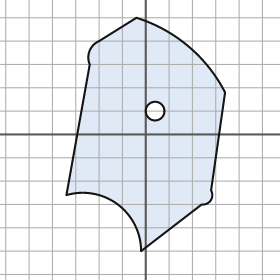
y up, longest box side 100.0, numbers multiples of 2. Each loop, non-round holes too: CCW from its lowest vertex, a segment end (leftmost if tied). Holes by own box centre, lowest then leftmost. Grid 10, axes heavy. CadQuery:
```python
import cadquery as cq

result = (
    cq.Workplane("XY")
    .moveTo(-2.0, -50.0)
    .lineTo(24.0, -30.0)
    .threePointArc((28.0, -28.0), (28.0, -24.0))
    .lineTo(34.0, 18.0)
    .threePointArc((18.0, 38.0), (-4.0, 50.0))
    .lineTo(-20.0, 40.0)
    .threePointArc((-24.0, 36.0), (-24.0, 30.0))
    .lineTo(-34.0, -26.0)
    .threePointArc((-12.0, -30.0), (-2.0, -50.0))
    .close()
    .moveTo(4.0, 10.0)
    .circle(4.0)
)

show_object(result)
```